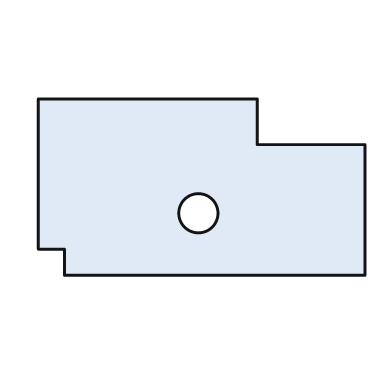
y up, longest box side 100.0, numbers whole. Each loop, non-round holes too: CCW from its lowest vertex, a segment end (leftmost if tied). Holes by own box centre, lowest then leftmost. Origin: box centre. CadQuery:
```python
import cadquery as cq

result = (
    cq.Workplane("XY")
    .moveTo(-42.0, -27.0)
    .lineTo(50.0, -27.0)
    .lineTo(50.0, 13.0)
    .lineTo(17.0, 13.0)
    .lineTo(17.0, 27.0)
    .lineTo(-50.0, 27.0)
    .lineTo(-50.0, -19.0)
    .lineTo(-42.0, -19.0)
    .close()
    .moveTo(-1.0, -8.0)
    .circle(6.0)
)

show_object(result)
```